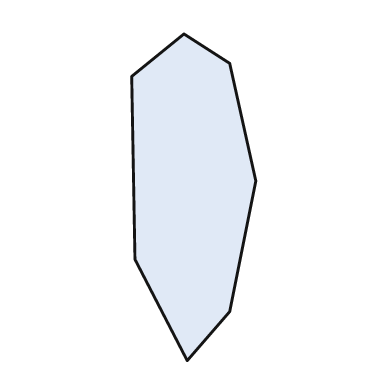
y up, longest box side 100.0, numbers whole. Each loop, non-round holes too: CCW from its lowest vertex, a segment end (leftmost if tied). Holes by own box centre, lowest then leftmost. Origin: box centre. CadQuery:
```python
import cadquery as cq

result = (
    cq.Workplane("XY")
    .moveTo(-2.0, -50.0)
    .lineTo(11.0, -35.0)
    .lineTo(19.0, 5.0)
    .lineTo(11.0, 41.0)
    .lineTo(-3.0, 50.0)
    .lineTo(-19.0, 37.0)
    .lineTo(-18.0, -19.0)
    .close()
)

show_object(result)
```